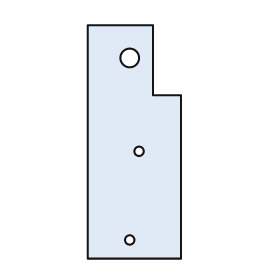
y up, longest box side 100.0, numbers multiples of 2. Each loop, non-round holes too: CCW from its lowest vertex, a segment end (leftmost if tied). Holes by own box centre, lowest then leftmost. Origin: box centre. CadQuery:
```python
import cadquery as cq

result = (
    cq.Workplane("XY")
    .moveTo(-20.0, -50.0)
    .lineTo(20.0, -50.0)
    .lineTo(20.0, 20.0)
    .lineTo(8.0, 20.0)
    .lineTo(8.0, 50.0)
    .lineTo(-20.0, 50.0)
    .close()
    .moveTo(-2.0, -42.0)
    .circle(2.0)
    .moveTo(2.0, -4.0)
    .circle(2.0)
    .moveTo(-2.0, 36.0)
    .circle(4.0)
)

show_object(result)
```